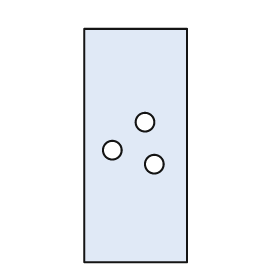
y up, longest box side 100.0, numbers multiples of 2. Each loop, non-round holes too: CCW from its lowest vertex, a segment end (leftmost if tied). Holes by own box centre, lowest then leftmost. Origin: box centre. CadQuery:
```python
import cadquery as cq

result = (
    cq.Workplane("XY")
    .moveTo(-22.0, -50.0)
    .lineTo(22.0, -50.0)
    .lineTo(22.0, 50.0)
    .lineTo(-22.0, 50.0)
    .close()
    .moveTo(8.0, -8.0)
    .circle(4.0)
    .moveTo(-10.0, -2.0)
    .circle(4.0)
    .moveTo(4.0, 10.0)
    .circle(4.0)
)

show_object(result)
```